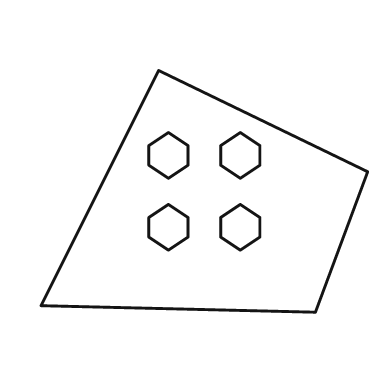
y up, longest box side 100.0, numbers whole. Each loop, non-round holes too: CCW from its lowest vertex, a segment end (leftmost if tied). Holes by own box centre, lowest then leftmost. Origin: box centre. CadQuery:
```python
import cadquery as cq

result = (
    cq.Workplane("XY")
    .moveTo(34.0, -37.0)
    .lineTo(50.0, 6.0)
    .lineTo(-14.0, 37.0)
    .lineTo(-50.0, -35.0)
    .close()
    .moveTo(-11.0, -18.0)
    .lineTo(-5.0, -14.0)
    .lineTo(-5.0, -8.0)
    .lineTo(-11.0, -4.0)
    .lineTo(-17.0, -8.0)
    .lineTo(-17.0, -14.0)
    .close()
    .moveTo(11.0, -18.0)
    .lineTo(17.0, -14.0)
    .lineTo(17.0, -8.0)
    .lineTo(11.0, -4.0)
    .lineTo(5.0, -8.0)
    .lineTo(5.0, -14.0)
    .close()
    .moveTo(-11.0, 4.0)
    .lineTo(-5.0, 8.0)
    .lineTo(-5.0, 14.0)
    .lineTo(-11.0, 18.0)
    .lineTo(-17.0, 14.0)
    .lineTo(-17.0, 8.0)
    .close()
    .moveTo(11.0, 4.0)
    .lineTo(17.0, 8.0)
    .lineTo(17.0, 14.0)
    .lineTo(11.0, 18.0)
    .lineTo(5.0, 14.0)
    .lineTo(5.0, 8.0)
    .close()
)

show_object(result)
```